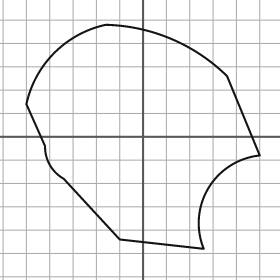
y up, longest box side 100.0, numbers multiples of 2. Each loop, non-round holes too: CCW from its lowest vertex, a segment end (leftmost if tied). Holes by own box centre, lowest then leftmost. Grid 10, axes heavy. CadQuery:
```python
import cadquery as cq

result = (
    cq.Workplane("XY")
    .moveTo(26.0, -48.0)
    .threePointArc((28.0, -22.0), (50.0, -8.0))
    .lineTo(36.0, 26.0)
    .threePointArc((12.0, 42.0), (-16.0, 48.0))
    .threePointArc((-38.0, 36.0), (-50.0, 14.0))
    .lineTo(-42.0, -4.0)
    .threePointArc((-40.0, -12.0), (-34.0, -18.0))
    .lineTo(-10.0, -44.0)
    .close()
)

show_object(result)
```